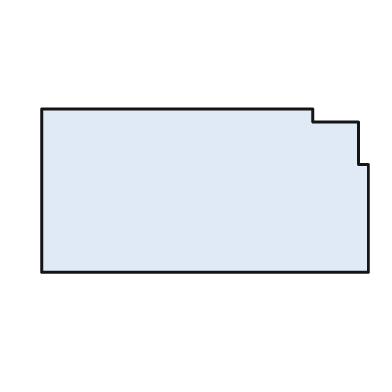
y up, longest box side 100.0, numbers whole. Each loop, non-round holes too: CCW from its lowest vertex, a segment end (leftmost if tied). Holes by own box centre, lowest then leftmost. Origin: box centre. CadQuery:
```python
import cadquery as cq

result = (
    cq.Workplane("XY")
    .moveTo(-50.0, -25.0)
    .lineTo(50.0, -25.0)
    .lineTo(50.0, 8.0)
    .lineTo(47.0, 8.0)
    .lineTo(47.0, 21.0)
    .lineTo(33.0, 21.0)
    .lineTo(33.0, 25.0)
    .lineTo(-50.0, 25.0)
    .close()
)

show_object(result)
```